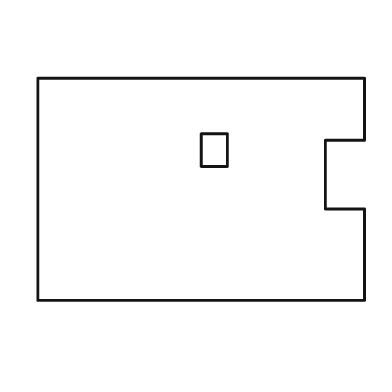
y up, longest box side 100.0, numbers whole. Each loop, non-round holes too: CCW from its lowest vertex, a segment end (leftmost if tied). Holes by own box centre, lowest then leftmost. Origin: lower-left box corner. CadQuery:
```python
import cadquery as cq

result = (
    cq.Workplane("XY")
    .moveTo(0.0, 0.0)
    .lineTo(100.0, 0.0)
    .lineTo(100.0, 28.0)
    .lineTo(88.0, 28.0)
    .lineTo(88.0, 49.0)
    .lineTo(100.0, 49.0)
    .lineTo(100.0, 68.0)
    .lineTo(0.0, 68.0)
    .close()
    .moveTo(50.0, 41.0)
    .lineTo(58.0, 41.0)
    .lineTo(58.0, 51.0)
    .lineTo(50.0, 51.0)
    .close()
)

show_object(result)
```